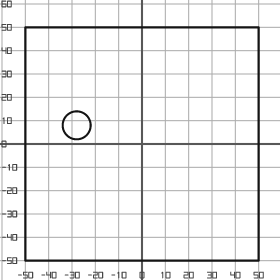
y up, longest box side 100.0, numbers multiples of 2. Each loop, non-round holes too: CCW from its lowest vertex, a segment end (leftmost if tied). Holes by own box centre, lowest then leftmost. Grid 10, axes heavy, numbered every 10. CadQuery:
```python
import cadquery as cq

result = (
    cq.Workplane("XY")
    .moveTo(-50.0, -50.0)
    .lineTo(50.0, -50.0)
    .lineTo(50.0, 50.0)
    .lineTo(-50.0, 50.0)
    .close()
    .moveTo(-28.0, 8.0)
    .circle(6.0)
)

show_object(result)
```